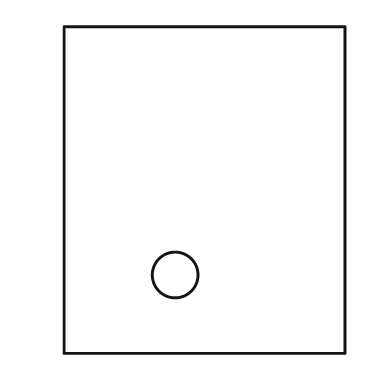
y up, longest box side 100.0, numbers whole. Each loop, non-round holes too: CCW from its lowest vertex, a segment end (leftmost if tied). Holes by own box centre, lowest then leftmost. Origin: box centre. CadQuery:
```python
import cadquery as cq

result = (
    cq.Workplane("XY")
    .moveTo(-43.0, -50.0)
    .lineTo(43.0, -50.0)
    .lineTo(43.0, 50.0)
    .lineTo(-43.0, 50.0)
    .close()
    .moveTo(-9.0, -26.0)
    .circle(7.0)
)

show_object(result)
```